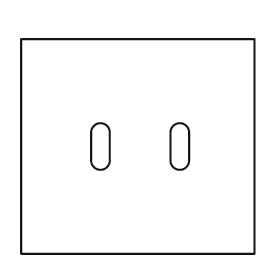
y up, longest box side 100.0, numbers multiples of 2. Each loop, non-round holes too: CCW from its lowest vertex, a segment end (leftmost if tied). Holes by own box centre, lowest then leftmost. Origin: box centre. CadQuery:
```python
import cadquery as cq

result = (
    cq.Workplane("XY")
    .moveTo(-50.0, -46.0)
    .lineTo(50.0, -46.0)
    .lineTo(50.0, 46.0)
    .lineTo(-50.0, 46.0)
    .close()
    .moveTo(-20.0, -6.0)
    .threePointArc((-16.0, -10.0), (-12.0, -6.0))
    .lineTo(-12.0, 6.0)
    .threePointArc((-16.0, 10.0), (-20.0, 6.0))
    .close()
    .moveTo(14.0, -6.0)
    .threePointArc((18.0, -10.0), (22.0, -6.0))
    .lineTo(22.0, 6.0)
    .threePointArc((18.0, 10.0), (14.0, 6.0))
    .close()
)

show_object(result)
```